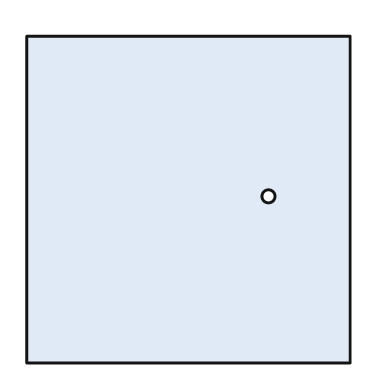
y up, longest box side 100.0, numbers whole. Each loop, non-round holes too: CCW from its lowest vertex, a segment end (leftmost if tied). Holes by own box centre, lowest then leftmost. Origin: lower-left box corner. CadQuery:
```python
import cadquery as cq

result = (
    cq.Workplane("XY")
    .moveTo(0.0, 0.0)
    .lineTo(99.0, 0.0)
    .lineTo(99.0, 100.0)
    .lineTo(0.0, 100.0)
    .close()
    .moveTo(74.0, 51.0)
    .circle(2.0)
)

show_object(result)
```